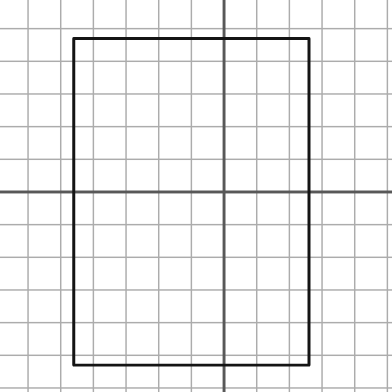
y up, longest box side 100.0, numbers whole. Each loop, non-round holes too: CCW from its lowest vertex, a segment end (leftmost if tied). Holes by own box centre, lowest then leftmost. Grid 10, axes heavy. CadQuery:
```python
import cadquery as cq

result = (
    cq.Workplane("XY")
    .moveTo(-46.0, -53.0)
    .lineTo(26.0, -53.0)
    .lineTo(26.0, 47.0)
    .lineTo(-46.0, 47.0)
    .close()
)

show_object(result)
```